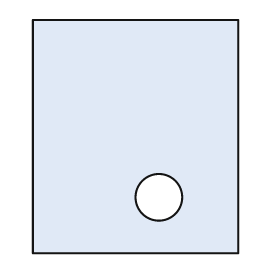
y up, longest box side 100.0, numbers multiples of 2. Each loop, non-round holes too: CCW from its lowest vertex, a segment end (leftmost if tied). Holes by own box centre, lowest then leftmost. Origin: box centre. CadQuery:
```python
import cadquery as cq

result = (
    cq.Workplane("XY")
    .moveTo(-44.0, -50.0)
    .lineTo(44.0, -50.0)
    .lineTo(44.0, 50.0)
    .lineTo(-44.0, 50.0)
    .close()
    .moveTo(10.0, -26.0)
    .circle(10.0)
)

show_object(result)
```